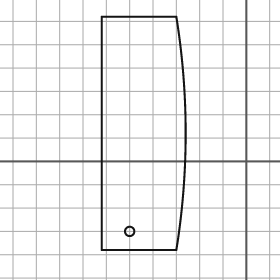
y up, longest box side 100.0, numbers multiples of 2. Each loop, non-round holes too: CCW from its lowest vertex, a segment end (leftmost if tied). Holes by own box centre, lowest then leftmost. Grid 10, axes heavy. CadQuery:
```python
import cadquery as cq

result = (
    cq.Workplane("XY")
    .moveTo(-62.0, -38.0)
    .lineTo(-30.0, -38.0)
    .threePointArc((-26.0, 12.0), (-30.0, 62.0))
    .lineTo(-62.0, 62.0)
    .close()
    .moveTo(-50.0, -30.0)
    .circle(2.0)
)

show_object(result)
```